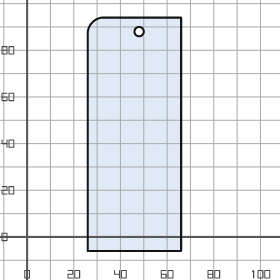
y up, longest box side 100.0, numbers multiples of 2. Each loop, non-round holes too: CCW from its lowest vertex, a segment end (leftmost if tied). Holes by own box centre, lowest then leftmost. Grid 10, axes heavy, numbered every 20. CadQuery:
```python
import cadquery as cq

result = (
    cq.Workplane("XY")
    .moveTo(26.0, -6.0)
    .lineTo(66.0, -6.0)
    .lineTo(66.0, 94.0)
    .lineTo(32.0, 94.0)
    .threePointArc((28.0, 92.0), (26.0, 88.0))
    .close()
    .moveTo(48.0, 88.0)
    .circle(2.0)
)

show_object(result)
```